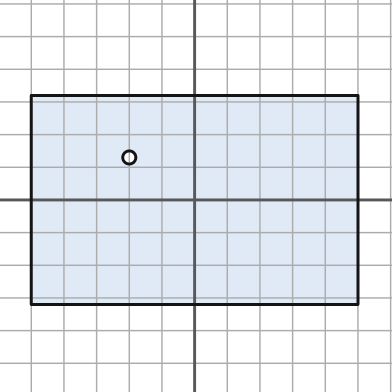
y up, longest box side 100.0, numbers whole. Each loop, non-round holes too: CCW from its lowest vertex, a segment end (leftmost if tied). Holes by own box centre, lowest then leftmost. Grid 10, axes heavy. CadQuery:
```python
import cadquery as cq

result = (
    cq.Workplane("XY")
    .moveTo(-50.0, -32.0)
    .lineTo(50.0, -32.0)
    .lineTo(50.0, 32.0)
    .lineTo(-50.0, 32.0)
    .close()
    .moveTo(-20.0, 13.0)
    .circle(2.0)
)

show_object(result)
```